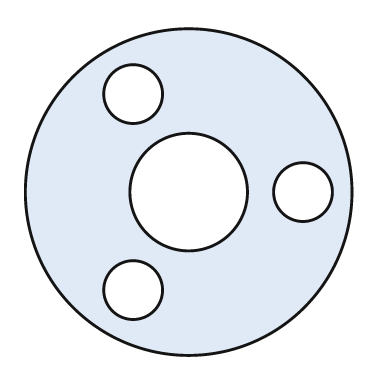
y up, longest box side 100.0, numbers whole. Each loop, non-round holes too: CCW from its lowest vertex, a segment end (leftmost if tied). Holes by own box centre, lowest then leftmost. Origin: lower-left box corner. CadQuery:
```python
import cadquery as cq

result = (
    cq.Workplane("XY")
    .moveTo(50.0, 50.0)
    .circle(50.0)
    .moveTo(33.0, 20.0)
    .circle(9.0)
    .moveTo(50.0, 50.0)
    .circle(18.0)
    .moveTo(85.0, 50.0)
    .circle(9.0)
    .moveTo(33.0, 80.0)
    .circle(9.0)
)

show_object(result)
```